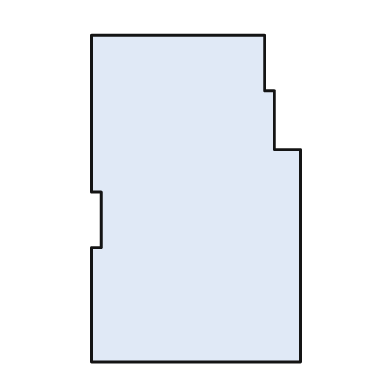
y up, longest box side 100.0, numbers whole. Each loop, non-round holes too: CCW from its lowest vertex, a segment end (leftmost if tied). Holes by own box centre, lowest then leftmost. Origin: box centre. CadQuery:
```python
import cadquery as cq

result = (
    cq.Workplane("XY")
    .moveTo(-32.0, -50.0)
    .lineTo(32.0, -50.0)
    .lineTo(32.0, 15.0)
    .lineTo(24.0, 15.0)
    .lineTo(24.0, 33.0)
    .lineTo(21.0, 33.0)
    .lineTo(21.0, 50.0)
    .lineTo(-32.0, 50.0)
    .lineTo(-32.0, 2.0)
    .lineTo(-29.0, 2.0)
    .lineTo(-29.0, -15.0)
    .lineTo(-32.0, -15.0)
    .close()
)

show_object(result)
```